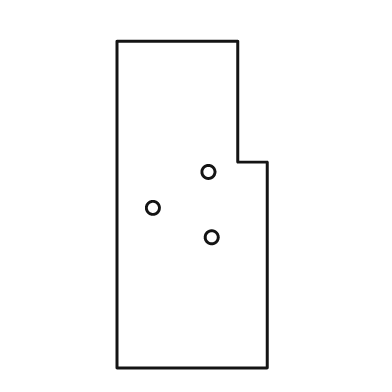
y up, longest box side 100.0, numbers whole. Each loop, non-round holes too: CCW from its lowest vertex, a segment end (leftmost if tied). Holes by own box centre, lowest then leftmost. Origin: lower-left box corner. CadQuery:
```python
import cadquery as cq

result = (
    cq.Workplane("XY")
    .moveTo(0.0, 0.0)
    .lineTo(46.0, 0.0)
    .lineTo(46.0, 63.0)
    .lineTo(37.0, 63.0)
    .lineTo(37.0, 100.0)
    .lineTo(0.0, 100.0)
    .close()
    .moveTo(29.0, 40.0)
    .circle(2.0)
    .moveTo(11.0, 49.0)
    .circle(2.0)
    .moveTo(28.0, 60.0)
    .circle(2.0)
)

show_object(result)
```